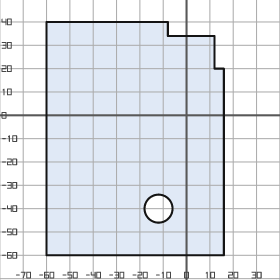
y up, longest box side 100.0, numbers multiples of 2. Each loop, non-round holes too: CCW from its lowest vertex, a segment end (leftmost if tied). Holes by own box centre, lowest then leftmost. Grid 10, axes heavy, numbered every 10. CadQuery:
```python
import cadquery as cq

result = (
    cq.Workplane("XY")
    .moveTo(-60.0, -60.0)
    .lineTo(16.0, -60.0)
    .lineTo(16.0, 20.0)
    .lineTo(12.0, 20.0)
    .lineTo(12.0, 34.0)
    .lineTo(-8.0, 34.0)
    .lineTo(-8.0, 40.0)
    .lineTo(-60.0, 40.0)
    .close()
    .moveTo(-12.0, -40.0)
    .circle(6.0)
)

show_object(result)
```